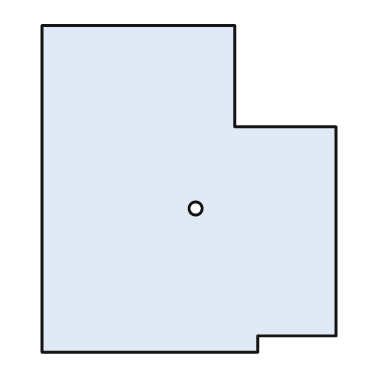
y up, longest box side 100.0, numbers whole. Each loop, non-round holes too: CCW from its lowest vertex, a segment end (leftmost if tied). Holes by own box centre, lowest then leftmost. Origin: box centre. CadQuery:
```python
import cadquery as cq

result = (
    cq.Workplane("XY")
    .moveTo(-45.0, -50.0)
    .lineTo(21.0, -50.0)
    .lineTo(21.0, -45.0)
    .lineTo(45.0, -45.0)
    .lineTo(45.0, 19.0)
    .lineTo(14.0, 19.0)
    .lineTo(14.0, 50.0)
    .lineTo(-45.0, 50.0)
    .close()
    .moveTo(2.0, -6.0)
    .circle(2.0)
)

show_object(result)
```